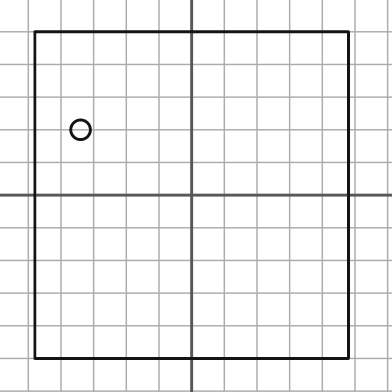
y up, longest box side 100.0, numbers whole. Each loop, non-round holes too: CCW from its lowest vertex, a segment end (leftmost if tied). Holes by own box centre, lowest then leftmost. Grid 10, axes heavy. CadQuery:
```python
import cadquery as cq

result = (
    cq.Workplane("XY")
    .moveTo(-48.0, -50.0)
    .lineTo(48.0, -50.0)
    .lineTo(48.0, 50.0)
    .lineTo(-48.0, 50.0)
    .close()
    .moveTo(-34.0, 20.0)
    .circle(3.0)
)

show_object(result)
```